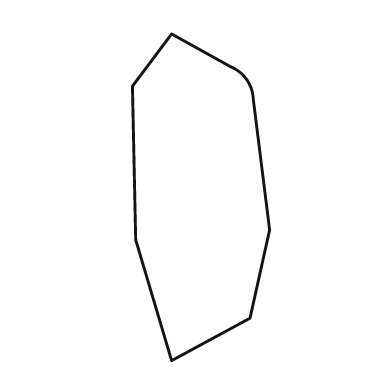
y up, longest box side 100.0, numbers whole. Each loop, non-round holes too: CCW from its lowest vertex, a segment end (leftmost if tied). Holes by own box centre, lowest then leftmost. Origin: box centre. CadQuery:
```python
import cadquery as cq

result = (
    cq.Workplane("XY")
    .moveTo(-9.0, -50.0)
    .lineTo(15.0, -37.0)
    .lineTo(21.0, -10.0)
    .lineTo(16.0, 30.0)
    .threePointArc((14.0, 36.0), (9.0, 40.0))
    .lineTo(-9.0, 50.0)
    .lineTo(-21.0, 34.0)
    .lineTo(-20.0, -13.0)
    .close()
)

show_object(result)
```